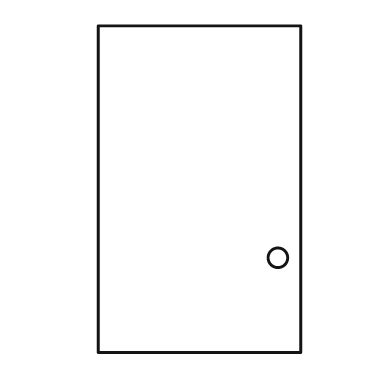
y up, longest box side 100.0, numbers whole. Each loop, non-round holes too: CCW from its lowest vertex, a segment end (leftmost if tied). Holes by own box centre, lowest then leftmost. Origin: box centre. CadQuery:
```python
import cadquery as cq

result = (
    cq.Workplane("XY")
    .moveTo(-31.0, -50.0)
    .lineTo(31.0, -50.0)
    .lineTo(31.0, 50.0)
    .lineTo(-31.0, 50.0)
    .close()
    .moveTo(24.0, -21.0)
    .circle(3.0)
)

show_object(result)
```